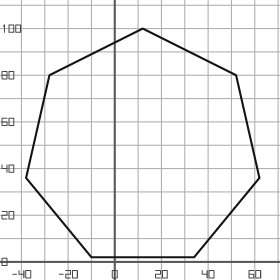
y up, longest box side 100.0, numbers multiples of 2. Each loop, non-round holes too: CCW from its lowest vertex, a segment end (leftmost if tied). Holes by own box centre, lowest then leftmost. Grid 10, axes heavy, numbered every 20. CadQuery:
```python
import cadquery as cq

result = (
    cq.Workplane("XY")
    .moveTo(-10.0, 2.0)
    .lineTo(34.0, 2.0)
    .lineTo(62.0, 36.0)
    .lineTo(52.0, 80.0)
    .lineTo(12.0, 100.0)
    .lineTo(-28.0, 80.0)
    .lineTo(-38.0, 36.0)
    .close()
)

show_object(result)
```